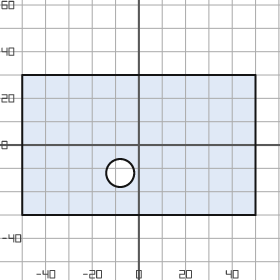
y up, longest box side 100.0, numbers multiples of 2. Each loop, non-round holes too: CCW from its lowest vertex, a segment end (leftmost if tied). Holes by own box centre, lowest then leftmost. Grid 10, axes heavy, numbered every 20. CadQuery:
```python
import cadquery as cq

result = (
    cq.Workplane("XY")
    .moveTo(-50.0, -30.0)
    .lineTo(50.0, -30.0)
    .lineTo(50.0, 30.0)
    .lineTo(-50.0, 30.0)
    .close()
    .moveTo(-8.0, -12.0)
    .circle(6.0)
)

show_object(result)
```